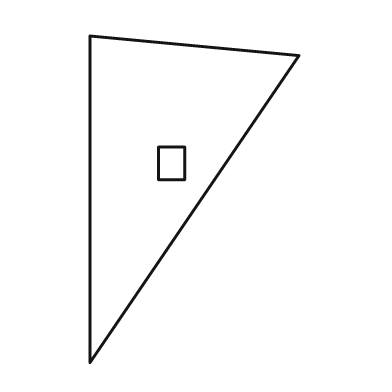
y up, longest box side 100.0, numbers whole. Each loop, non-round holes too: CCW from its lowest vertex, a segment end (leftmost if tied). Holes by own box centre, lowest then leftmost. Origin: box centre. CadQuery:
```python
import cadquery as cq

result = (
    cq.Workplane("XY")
    .moveTo(-32.0, -50.0)
    .lineTo(32.0, 44.0)
    .lineTo(-32.0, 50.0)
    .close()
    .moveTo(-11.0, 6.0)
    .lineTo(-3.0, 6.0)
    .lineTo(-3.0, 16.0)
    .lineTo(-11.0, 16.0)
    .close()
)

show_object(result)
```